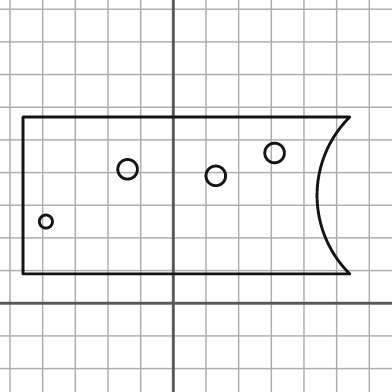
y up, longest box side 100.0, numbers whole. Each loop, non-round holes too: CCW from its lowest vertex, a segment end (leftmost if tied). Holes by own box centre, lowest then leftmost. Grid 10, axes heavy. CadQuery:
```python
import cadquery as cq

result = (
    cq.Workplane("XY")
    .moveTo(-46.0, 9.0)
    .lineTo(54.0, 9.0)
    .threePointArc((44.0, 33.0), (54.0, 57.0))
    .lineTo(-46.0, 57.0)
    .close()
    .moveTo(-39.0, 25.0)
    .circle(2.0)
    .moveTo(13.0, 39.0)
    .circle(3.0)
    .moveTo(-14.0, 41.0)
    .circle(3.0)
    .moveTo(31.0, 46.0)
    .circle(3.0)
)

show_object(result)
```